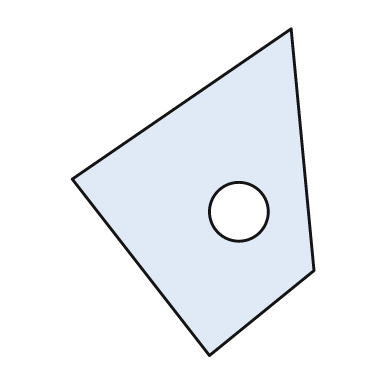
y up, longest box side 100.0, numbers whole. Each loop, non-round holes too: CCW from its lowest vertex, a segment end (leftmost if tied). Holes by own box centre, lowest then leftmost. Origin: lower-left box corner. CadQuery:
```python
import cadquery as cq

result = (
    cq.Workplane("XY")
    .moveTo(42.0, 0.0)
    .lineTo(74.0, 26.0)
    .lineTo(67.0, 100.0)
    .lineTo(0.0, 54.0)
    .close()
    .moveTo(51.0, 44.0)
    .circle(9.0)
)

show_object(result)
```